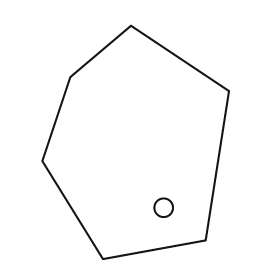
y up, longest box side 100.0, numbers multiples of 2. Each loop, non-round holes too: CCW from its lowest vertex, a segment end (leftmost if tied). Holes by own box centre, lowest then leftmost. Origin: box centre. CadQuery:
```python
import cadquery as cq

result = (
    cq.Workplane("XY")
    .moveTo(-14.0, -50.0)
    .lineTo(30.0, -42.0)
    .lineTo(40.0, 22.0)
    .lineTo(-2.0, 50.0)
    .lineTo(-28.0, 28.0)
    .lineTo(-40.0, -8.0)
    .close()
    .moveTo(12.0, -28.0)
    .circle(4.0)
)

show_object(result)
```